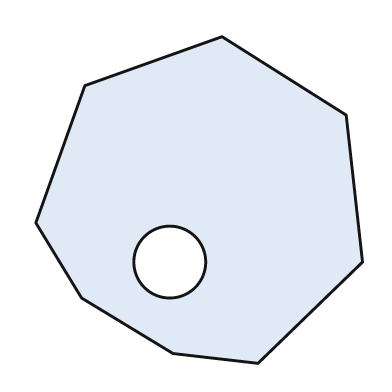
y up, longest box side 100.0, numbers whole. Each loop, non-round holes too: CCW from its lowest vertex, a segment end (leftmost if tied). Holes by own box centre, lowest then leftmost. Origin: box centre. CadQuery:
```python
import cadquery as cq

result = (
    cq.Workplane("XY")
    .moveTo(18.0, -50.0)
    .lineTo(50.0, -19.0)
    .lineTo(45.0, 26.0)
    .lineTo(7.0, 50.0)
    .lineTo(-35.0, 35.0)
    .lineTo(-50.0, -7.0)
    .lineTo(-36.0, -30.0)
    .lineTo(-8.0, -47.0)
    .close()
    .moveTo(-9.0, -19.0)
    .circle(11.0)
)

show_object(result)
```